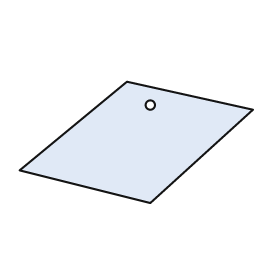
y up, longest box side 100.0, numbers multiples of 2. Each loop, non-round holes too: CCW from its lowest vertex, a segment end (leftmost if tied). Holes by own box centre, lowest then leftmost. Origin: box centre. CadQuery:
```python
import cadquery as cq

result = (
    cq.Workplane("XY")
    .moveTo(6.0, -26.0)
    .lineTo(50.0, 14.0)
    .lineTo(-4.0, 26.0)
    .lineTo(-50.0, -12.0)
    .close()
    .moveTo(6.0, 16.0)
    .circle(2.0)
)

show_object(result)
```